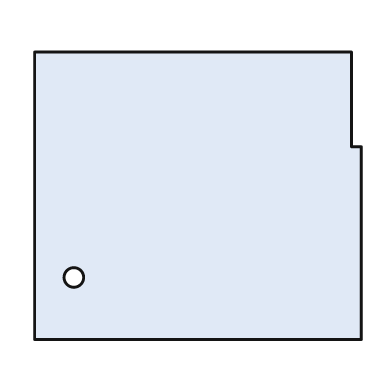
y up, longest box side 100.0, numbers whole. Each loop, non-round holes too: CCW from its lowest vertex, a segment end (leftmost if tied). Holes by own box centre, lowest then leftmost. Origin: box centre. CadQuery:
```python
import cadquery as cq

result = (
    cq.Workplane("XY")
    .moveTo(-50.0, -44.0)
    .lineTo(50.0, -44.0)
    .lineTo(50.0, 15.0)
    .lineTo(47.0, 15.0)
    .lineTo(47.0, 44.0)
    .lineTo(-50.0, 44.0)
    .close()
    .moveTo(-38.0, -25.0)
    .circle(3.0)
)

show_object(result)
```